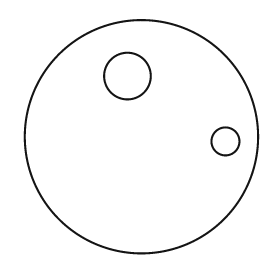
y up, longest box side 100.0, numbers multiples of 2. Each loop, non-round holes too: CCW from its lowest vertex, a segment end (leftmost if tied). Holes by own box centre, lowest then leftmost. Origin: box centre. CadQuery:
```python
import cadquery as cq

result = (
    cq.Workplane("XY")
    .moveTo(0.0, 0.0)
    .circle(50.0)
    .moveTo(36.0, -2.0)
    .circle(6.0)
    .moveTo(-6.0, 26.0)
    .circle(10.0)
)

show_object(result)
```